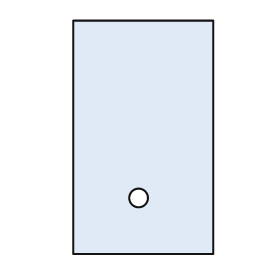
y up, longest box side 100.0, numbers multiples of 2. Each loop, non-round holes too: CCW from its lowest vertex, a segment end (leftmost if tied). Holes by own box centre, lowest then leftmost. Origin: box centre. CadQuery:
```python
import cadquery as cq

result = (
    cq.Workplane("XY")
    .moveTo(-30.0, -50.0)
    .lineTo(30.0, -50.0)
    .lineTo(30.0, 50.0)
    .lineTo(-30.0, 50.0)
    .close()
    .moveTo(-2.0, -26.0)
    .circle(4.0)
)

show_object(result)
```